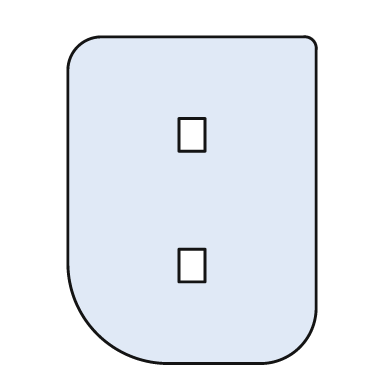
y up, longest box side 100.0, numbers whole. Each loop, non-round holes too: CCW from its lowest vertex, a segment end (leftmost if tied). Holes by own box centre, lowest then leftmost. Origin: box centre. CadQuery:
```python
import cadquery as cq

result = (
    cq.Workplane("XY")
    .moveTo(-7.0, -50.0)
    .lineTo(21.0, -50.0)
    .threePointArc((33.0, -45.0), (38.0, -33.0))
    .lineTo(38.0, 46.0)
    .threePointArc((37.0, 49.0), (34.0, 50.0))
    .lineTo(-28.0, 50.0)
    .threePointArc((-35.0, 47.0), (-38.0, 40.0))
    .lineTo(-38.0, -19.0)
    .threePointArc((-29.0, -41.0), (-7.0, -50.0))
    .close()
    .moveTo(-4.0, -25.0)
    .lineTo(4.0, -25.0)
    .lineTo(4.0, -15.0)
    .lineTo(-4.0, -15.0)
    .close()
    .moveTo(-4.0, 15.0)
    .lineTo(4.0, 15.0)
    .lineTo(4.0, 25.0)
    .lineTo(-4.0, 25.0)
    .close()
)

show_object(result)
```